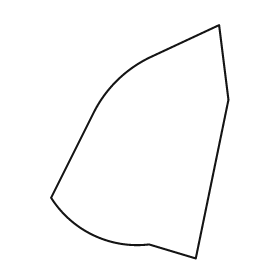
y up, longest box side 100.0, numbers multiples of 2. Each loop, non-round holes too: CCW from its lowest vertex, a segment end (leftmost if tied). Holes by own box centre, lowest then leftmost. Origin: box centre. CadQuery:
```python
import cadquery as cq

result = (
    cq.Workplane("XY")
    .moveTo(24.0, -50.0)
    .lineTo(38.0, 18.0)
    .lineTo(34.0, 50.0)
    .lineTo(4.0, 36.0)
    .threePointArc((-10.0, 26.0), (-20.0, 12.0))
    .lineTo(-38.0, -24.0)
    .threePointArc((-20.0, -40.0), (4.0, -44.0))
    .close()
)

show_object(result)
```